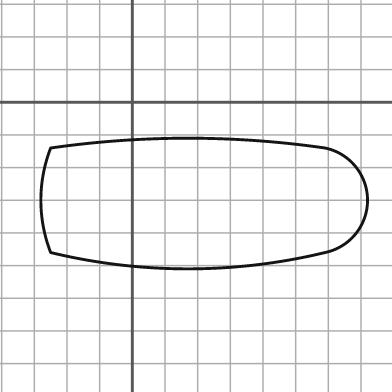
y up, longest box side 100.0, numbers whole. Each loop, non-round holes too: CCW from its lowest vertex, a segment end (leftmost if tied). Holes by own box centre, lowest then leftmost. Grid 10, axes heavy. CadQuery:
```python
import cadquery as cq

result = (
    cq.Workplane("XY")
    .moveTo(-25.0, -46.0)
    .threePointArc((17.0, -51.0), (59.0, -46.0))
    .threePointArc((72.0, -30.0), (59.0, -14.0))
    .threePointArc((17.0, -11.0), (-25.0, -14.0))
    .threePointArc((-28.0, -30.0), (-25.0, -46.0))
    .close()
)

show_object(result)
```